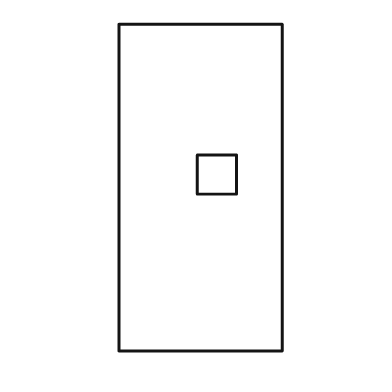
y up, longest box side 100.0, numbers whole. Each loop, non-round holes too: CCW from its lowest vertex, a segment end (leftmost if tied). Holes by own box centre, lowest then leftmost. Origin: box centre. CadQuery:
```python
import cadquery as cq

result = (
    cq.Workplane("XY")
    .moveTo(-25.0, -50.0)
    .lineTo(25.0, -50.0)
    .lineTo(25.0, 50.0)
    .lineTo(-25.0, 50.0)
    .close()
    .moveTo(-1.0, -2.0)
    .lineTo(11.0, -2.0)
    .lineTo(11.0, 10.0)
    .lineTo(-1.0, 10.0)
    .close()
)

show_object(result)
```